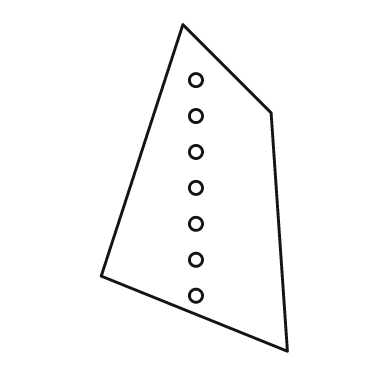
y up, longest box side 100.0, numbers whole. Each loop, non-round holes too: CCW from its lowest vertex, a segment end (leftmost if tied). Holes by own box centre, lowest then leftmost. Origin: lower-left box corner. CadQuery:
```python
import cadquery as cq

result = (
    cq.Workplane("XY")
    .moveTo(57.0, 0.0)
    .lineTo(52.0, 73.0)
    .lineTo(25.0, 100.0)
    .lineTo(0.0, 23.0)
    .close()
    .moveTo(29.0, 17.0)
    .circle(2.0)
    .moveTo(29.0, 28.0)
    .circle(2.0)
    .moveTo(29.0, 39.0)
    .circle(2.0)
    .moveTo(29.0, 50.0)
    .circle(2.0)
    .moveTo(29.0, 61.0)
    .circle(2.0)
    .moveTo(29.0, 72.0)
    .circle(2.0)
    .moveTo(29.0, 83.0)
    .circle(2.0)
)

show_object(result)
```